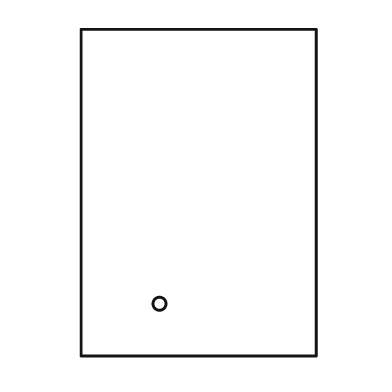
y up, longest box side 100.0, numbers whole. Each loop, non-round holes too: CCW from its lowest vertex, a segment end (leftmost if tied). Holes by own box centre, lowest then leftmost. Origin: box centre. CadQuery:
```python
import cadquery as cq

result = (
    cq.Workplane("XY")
    .moveTo(-36.0, -50.0)
    .lineTo(36.0, -50.0)
    .lineTo(36.0, 50.0)
    .lineTo(-36.0, 50.0)
    .close()
    .moveTo(-12.0, -34.0)
    .circle(2.0)
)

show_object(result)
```